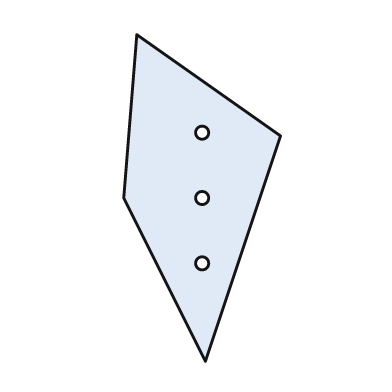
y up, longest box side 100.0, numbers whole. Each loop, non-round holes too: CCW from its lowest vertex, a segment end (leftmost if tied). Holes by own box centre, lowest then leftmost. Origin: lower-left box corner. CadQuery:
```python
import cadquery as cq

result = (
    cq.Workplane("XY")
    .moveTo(25.0, 0.0)
    .lineTo(48.0, 69.0)
    .lineTo(4.0, 100.0)
    .lineTo(0.0, 50.0)
    .close()
    .moveTo(24.0, 30.0)
    .circle(2.0)
    .moveTo(24.0, 50.0)
    .circle(2.0)
    .moveTo(24.0, 70.0)
    .circle(2.0)
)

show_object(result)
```